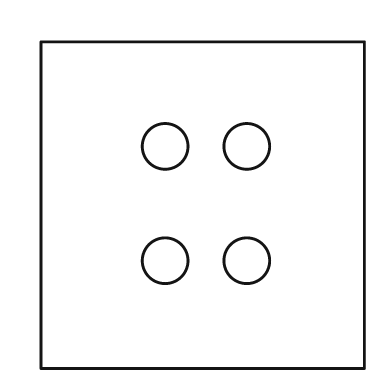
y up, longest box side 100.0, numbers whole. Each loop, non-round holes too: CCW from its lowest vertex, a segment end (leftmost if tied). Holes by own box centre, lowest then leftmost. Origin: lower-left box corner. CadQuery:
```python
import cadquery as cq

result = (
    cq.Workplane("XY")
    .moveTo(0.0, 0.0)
    .lineTo(99.0, 0.0)
    .lineTo(99.0, 100.0)
    .lineTo(0.0, 100.0)
    .close()
    .moveTo(38.0, 33.0)
    .circle(7.0)
    .moveTo(63.0, 33.0)
    .circle(7.0)
    .moveTo(38.0, 68.0)
    .circle(7.0)
    .moveTo(63.0, 68.0)
    .circle(7.0)
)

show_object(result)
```